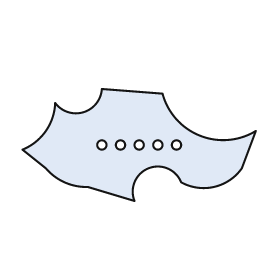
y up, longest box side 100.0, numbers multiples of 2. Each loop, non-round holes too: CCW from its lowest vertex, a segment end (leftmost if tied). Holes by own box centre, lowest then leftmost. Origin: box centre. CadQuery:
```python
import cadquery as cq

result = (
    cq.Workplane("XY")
    .moveTo(-2.0, -24.0)
    .threePointArc((4.0, -10.0), (18.0, -16.0))
    .threePointArc((32.0, -18.0), (44.0, -10.0))
    .lineTo(50.0, 6.0)
    .threePointArc((26.0, 4.0), (10.0, 22.0))
    .lineTo(-16.0, 24.0)
    .threePointArc((-24.0, 14.0), (-36.0, 18.0))
    .threePointArc((-40.0, 6.0), (-50.0, -2.0))
    .lineTo(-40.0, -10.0)
    .threePointArc((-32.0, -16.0), (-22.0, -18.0))
    .close()
    .moveTo(-16.0, 0.0)
    .circle(2.0)
    .moveTo(-8.0, 0.0)
    .circle(2.0)
    .moveTo(0.0, 0.0)
    .circle(2.0)
    .moveTo(8.0, 0.0)
    .circle(2.0)
    .moveTo(16.0, 0.0)
    .circle(2.0)
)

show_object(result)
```